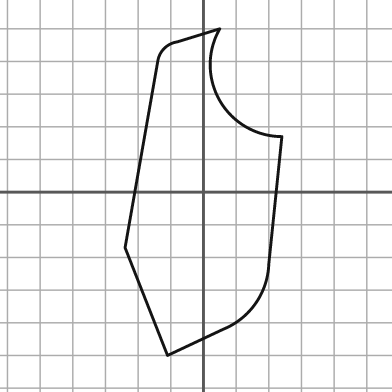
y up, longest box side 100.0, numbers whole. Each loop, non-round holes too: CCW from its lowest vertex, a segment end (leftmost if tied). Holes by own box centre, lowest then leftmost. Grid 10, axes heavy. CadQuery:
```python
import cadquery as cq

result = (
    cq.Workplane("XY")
    .moveTo(-11.0, -50.0)
    .lineTo(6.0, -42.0)
    .threePointArc((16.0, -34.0), (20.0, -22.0))
    .lineTo(24.0, 17.0)
    .threePointArc((5.0, 28.0), (5.0, 50.0))
    .lineTo(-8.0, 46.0)
    .threePointArc((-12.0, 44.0), (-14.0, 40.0))
    .lineTo(-24.0, -17.0)
    .close()
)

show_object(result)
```